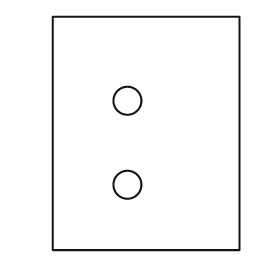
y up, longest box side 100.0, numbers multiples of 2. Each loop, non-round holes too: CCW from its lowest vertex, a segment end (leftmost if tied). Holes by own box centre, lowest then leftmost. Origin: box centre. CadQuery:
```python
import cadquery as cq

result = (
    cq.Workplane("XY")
    .moveTo(-40.0, -50.0)
    .lineTo(40.0, -50.0)
    .lineTo(40.0, 50.0)
    .lineTo(-40.0, 50.0)
    .close()
    .moveTo(-8.0, -22.0)
    .circle(6.0)
    .moveTo(-8.0, 14.0)
    .circle(6.0)
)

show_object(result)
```